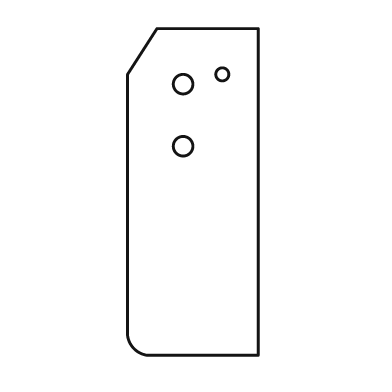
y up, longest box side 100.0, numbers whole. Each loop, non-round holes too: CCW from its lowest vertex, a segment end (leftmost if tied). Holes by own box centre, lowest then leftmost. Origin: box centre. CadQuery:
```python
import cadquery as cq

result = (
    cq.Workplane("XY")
    .moveTo(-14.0, -50.0)
    .lineTo(20.0, -50.0)
    .lineTo(20.0, 50.0)
    .lineTo(-11.0, 50.0)
    .lineTo(-20.0, 36.0)
    .lineTo(-20.0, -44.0)
    .threePointArc((-18.0, -48.0), (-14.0, -50.0))
    .close()
    .moveTo(-3.0, 14.0)
    .circle(3.0)
    .moveTo(-3.0, 33.0)
    .circle(3.0)
    .moveTo(9.0, 36.0)
    .circle(2.0)
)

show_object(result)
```